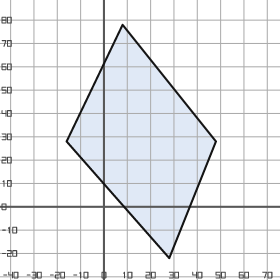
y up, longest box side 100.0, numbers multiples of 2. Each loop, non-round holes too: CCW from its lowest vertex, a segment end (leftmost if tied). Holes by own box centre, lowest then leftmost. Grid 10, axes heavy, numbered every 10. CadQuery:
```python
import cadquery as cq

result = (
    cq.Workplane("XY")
    .moveTo(28.0, -22.0)
    .lineTo(48.0, 28.0)
    .lineTo(8.0, 78.0)
    .lineTo(-16.0, 28.0)
    .close()
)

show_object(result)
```